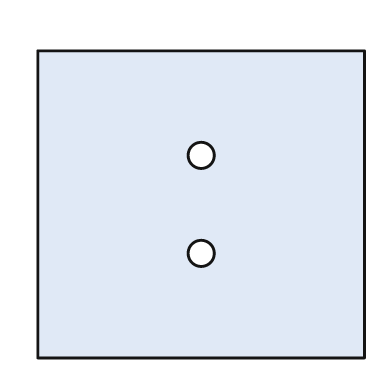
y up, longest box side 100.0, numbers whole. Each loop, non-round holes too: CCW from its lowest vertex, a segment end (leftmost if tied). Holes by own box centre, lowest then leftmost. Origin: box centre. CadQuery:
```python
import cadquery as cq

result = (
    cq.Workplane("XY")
    .moveTo(-50.0, -47.0)
    .lineTo(50.0, -47.0)
    .lineTo(50.0, 47.0)
    .lineTo(-50.0, 47.0)
    .close()
    .moveTo(0.0, -15.0)
    .circle(4.0)
    .moveTo(0.0, 15.0)
    .circle(4.0)
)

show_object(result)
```